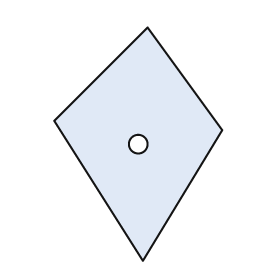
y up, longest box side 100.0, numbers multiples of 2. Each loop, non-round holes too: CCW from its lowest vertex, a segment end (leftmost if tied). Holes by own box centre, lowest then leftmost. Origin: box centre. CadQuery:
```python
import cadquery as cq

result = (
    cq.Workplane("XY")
    .moveTo(2.0, -50.0)
    .lineTo(36.0, 6.0)
    .lineTo(4.0, 50.0)
    .lineTo(-36.0, 10.0)
    .close()
    .moveTo(0.0, 0.0)
    .circle(4.0)
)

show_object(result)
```